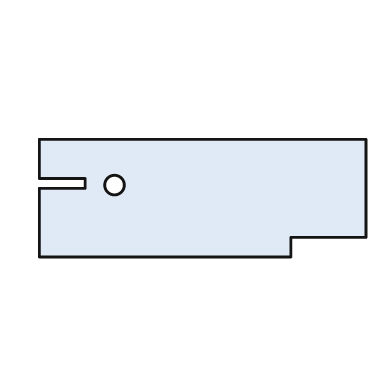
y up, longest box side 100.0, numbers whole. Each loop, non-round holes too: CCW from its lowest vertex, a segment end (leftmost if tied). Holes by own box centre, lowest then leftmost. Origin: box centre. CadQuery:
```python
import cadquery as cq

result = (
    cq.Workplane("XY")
    .moveTo(-50.0, -18.0)
    .lineTo(27.0, -18.0)
    .lineTo(27.0, -12.0)
    .lineTo(50.0, -12.0)
    .lineTo(50.0, 18.0)
    .lineTo(-50.0, 18.0)
    .lineTo(-50.0, 6.0)
    .lineTo(-36.0, 6.0)
    .lineTo(-36.0, 3.0)
    .lineTo(-50.0, 3.0)
    .close()
    .moveTo(-27.0, 4.0)
    .circle(3.0)
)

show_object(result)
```